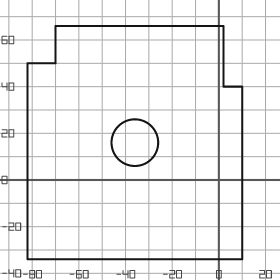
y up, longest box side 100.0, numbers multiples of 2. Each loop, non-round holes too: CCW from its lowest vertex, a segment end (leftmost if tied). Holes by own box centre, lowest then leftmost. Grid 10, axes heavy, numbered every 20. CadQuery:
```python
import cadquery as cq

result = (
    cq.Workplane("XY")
    .moveTo(-82.0, -34.0)
    .lineTo(10.0, -34.0)
    .lineTo(10.0, 40.0)
    .lineTo(2.0, 40.0)
    .lineTo(2.0, 66.0)
    .lineTo(-70.0, 66.0)
    .lineTo(-70.0, 50.0)
    .lineTo(-82.0, 50.0)
    .close()
    .moveTo(-36.0, 16.0)
    .circle(10.0)
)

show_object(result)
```